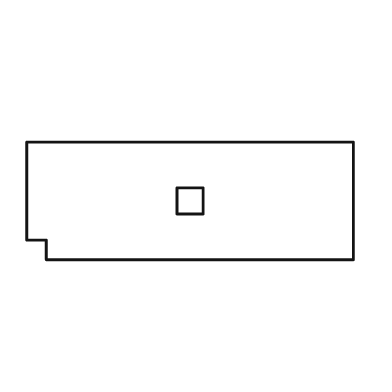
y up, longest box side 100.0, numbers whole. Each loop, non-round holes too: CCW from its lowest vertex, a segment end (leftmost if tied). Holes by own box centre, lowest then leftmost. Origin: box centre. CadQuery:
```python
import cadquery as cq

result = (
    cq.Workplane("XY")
    .moveTo(-44.0, -18.0)
    .lineTo(50.0, -18.0)
    .lineTo(50.0, 18.0)
    .lineTo(-50.0, 18.0)
    .lineTo(-50.0, -12.0)
    .lineTo(-44.0, -12.0)
    .close()
    .moveTo(-4.0, -4.0)
    .lineTo(4.0, -4.0)
    .lineTo(4.0, 4.0)
    .lineTo(-4.0, 4.0)
    .close()
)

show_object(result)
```